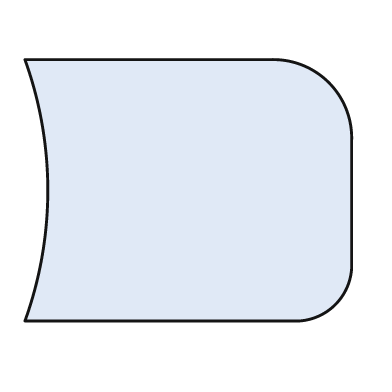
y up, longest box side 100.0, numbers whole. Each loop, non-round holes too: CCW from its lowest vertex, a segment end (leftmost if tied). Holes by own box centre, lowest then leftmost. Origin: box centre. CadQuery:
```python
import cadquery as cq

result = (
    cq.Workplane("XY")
    .moveTo(-50.0, -40.0)
    .lineTo(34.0, -40.0)
    .threePointArc((45.0, -35.0), (50.0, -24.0))
    .lineTo(50.0, 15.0)
    .threePointArc((43.0, 33.0), (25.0, 40.0))
    .lineTo(-50.0, 40.0)
    .threePointArc((-43.0, 0.0), (-50.0, -40.0))
    .close()
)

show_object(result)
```